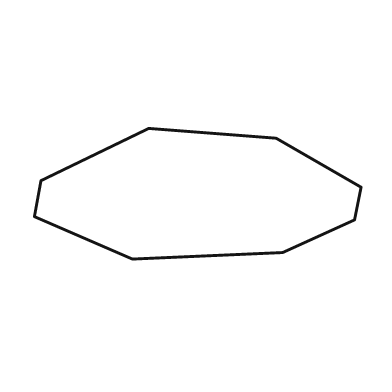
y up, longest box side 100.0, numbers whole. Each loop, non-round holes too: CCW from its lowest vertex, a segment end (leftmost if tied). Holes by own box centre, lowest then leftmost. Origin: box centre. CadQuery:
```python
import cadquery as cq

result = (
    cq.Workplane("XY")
    .moveTo(-20.0, -20.0)
    .lineTo(26.0, -18.0)
    .lineTo(48.0, -8.0)
    .lineTo(50.0, 2.0)
    .lineTo(24.0, 17.0)
    .lineTo(-15.0, 20.0)
    .lineTo(-48.0, 4.0)
    .lineTo(-50.0, -7.0)
    .close()
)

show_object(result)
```